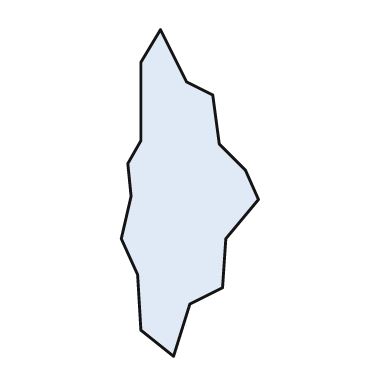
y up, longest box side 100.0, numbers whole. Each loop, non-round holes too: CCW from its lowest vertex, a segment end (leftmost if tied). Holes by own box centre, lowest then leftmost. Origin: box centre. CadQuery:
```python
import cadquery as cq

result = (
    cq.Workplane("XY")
    .moveTo(-5.0, -50.0)
    .lineTo(0.0, -34.0)
    .lineTo(10.0, -29.0)
    .lineTo(11.0, -14.0)
    .lineTo(21.0, -2.0)
    .lineTo(17.0, 7.0)
    .lineTo(9.0, 15.0)
    .lineTo(7.0, 30.0)
    .lineTo(-1.0, 34.0)
    .lineTo(-9.0, 50.0)
    .lineTo(-15.0, 40.0)
    .lineTo(-15.0, 16.0)
    .lineTo(-19.0, 9.0)
    .lineTo(-18.0, -1.0)
    .lineTo(-21.0, -14.0)
    .lineTo(-16.0, -25.0)
    .lineTo(-15.0, -42.0)
    .close()
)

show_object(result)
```